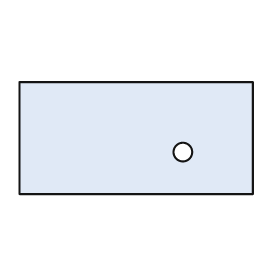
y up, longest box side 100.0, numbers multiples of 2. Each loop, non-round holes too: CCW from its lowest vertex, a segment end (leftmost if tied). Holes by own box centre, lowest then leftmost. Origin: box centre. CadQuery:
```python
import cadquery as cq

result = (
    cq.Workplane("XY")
    .moveTo(-50.0, -24.0)
    .lineTo(50.0, -24.0)
    .lineTo(50.0, 24.0)
    .lineTo(-50.0, 24.0)
    .close()
    .moveTo(20.0, -6.0)
    .circle(4.0)
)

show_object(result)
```